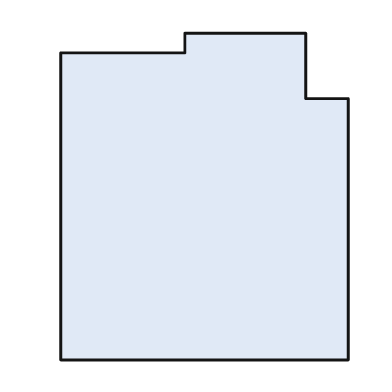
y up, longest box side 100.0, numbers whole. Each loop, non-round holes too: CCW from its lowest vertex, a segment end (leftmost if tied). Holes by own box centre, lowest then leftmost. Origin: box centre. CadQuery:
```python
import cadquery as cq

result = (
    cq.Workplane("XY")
    .moveTo(-44.0, -50.0)
    .lineTo(44.0, -50.0)
    .lineTo(44.0, 30.0)
    .lineTo(31.0, 30.0)
    .lineTo(31.0, 50.0)
    .lineTo(-6.0, 50.0)
    .lineTo(-6.0, 44.0)
    .lineTo(-44.0, 44.0)
    .close()
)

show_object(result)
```